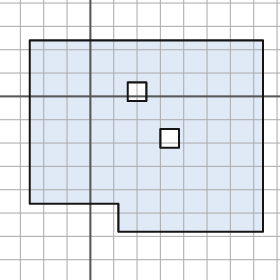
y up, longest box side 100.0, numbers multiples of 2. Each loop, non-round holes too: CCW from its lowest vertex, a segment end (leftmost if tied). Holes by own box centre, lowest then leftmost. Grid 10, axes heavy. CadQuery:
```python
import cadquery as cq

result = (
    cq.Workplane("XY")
    .moveTo(12.0, -58.0)
    .lineTo(74.0, -58.0)
    .lineTo(74.0, 24.0)
    .lineTo(-26.0, 24.0)
    .lineTo(-26.0, -46.0)
    .lineTo(12.0, -46.0)
    .close()
    .moveTo(30.0, -22.0)
    .lineTo(38.0, -22.0)
    .lineTo(38.0, -14.0)
    .lineTo(30.0, -14.0)
    .close()
    .moveTo(16.0, -2.0)
    .lineTo(24.0, -2.0)
    .lineTo(24.0, 6.0)
    .lineTo(16.0, 6.0)
    .close()
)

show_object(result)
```